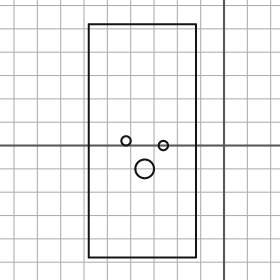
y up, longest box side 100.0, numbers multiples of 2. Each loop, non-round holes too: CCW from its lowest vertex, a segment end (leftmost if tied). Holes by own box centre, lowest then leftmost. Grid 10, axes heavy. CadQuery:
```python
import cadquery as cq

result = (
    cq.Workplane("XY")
    .moveTo(-58.0, -48.0)
    .lineTo(-12.0, -48.0)
    .lineTo(-12.0, 52.0)
    .lineTo(-58.0, 52.0)
    .close()
    .moveTo(-34.0, -10.0)
    .circle(4.0)
    .moveTo(-26.0, 0.0)
    .circle(2.0)
    .moveTo(-42.0, 2.0)
    .circle(2.0)
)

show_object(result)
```